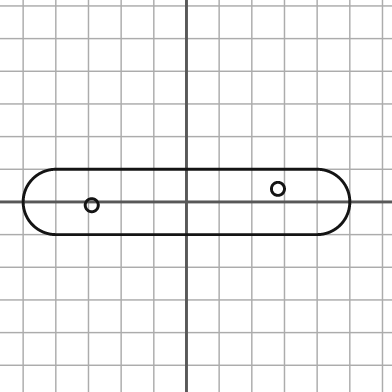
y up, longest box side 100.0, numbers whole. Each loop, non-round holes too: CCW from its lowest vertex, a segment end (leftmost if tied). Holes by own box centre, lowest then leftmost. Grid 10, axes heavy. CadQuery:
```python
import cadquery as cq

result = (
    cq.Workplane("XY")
    .moveTo(-40.0, -10.0)
    .lineTo(40.0, -10.0)
    .threePointArc((50.0, 0.0), (40.0, 10.0))
    .lineTo(-40.0, 10.0)
    .threePointArc((-50.0, 0.0), (-40.0, -10.0))
    .close()
    .moveTo(-29.0, -1.0)
    .circle(2.0)
    .moveTo(28.0, 4.0)
    .circle(2.0)
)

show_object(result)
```